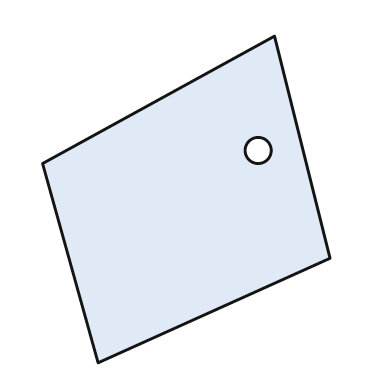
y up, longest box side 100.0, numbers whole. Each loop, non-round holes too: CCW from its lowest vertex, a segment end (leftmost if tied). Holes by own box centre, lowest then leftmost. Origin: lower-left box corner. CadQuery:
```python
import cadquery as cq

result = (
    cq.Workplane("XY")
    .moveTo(17.0, 0.0)
    .lineTo(88.0, 32.0)
    .lineTo(71.0, 100.0)
    .lineTo(0.0, 61.0)
    .close()
    .moveTo(66.0, 65.0)
    .circle(4.0)
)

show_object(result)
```